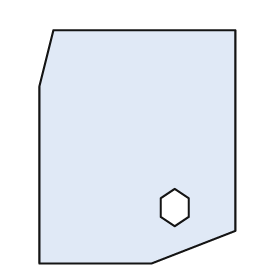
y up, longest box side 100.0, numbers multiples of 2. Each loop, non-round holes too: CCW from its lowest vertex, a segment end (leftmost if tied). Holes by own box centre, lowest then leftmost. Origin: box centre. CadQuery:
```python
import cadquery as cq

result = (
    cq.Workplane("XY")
    .moveTo(-42.0, -50.0)
    .lineTo(6.0, -50.0)
    .lineTo(42.0, -36.0)
    .lineTo(42.0, 50.0)
    .lineTo(-36.0, 50.0)
    .lineTo(-42.0, 26.0)
    .close()
    .moveTo(16.0, -34.0)
    .lineTo(22.0, -30.0)
    .lineTo(22.0, -22.0)
    .lineTo(16.0, -18.0)
    .lineTo(10.0, -22.0)
    .lineTo(10.0, -30.0)
    .close()
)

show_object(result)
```